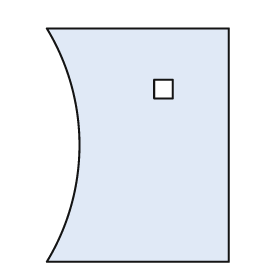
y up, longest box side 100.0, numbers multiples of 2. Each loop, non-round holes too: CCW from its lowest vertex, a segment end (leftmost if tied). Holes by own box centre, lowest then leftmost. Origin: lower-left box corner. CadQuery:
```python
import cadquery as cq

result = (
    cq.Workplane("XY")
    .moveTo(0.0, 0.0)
    .lineTo(78.0, 0.0)
    .lineTo(78.0, 100.0)
    .lineTo(0.0, 100.0)
    .threePointArc((14.0, 50.0), (0.0, 0.0))
    .close()
    .moveTo(46.0, 70.0)
    .lineTo(54.0, 70.0)
    .lineTo(54.0, 78.0)
    .lineTo(46.0, 78.0)
    .close()
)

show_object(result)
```